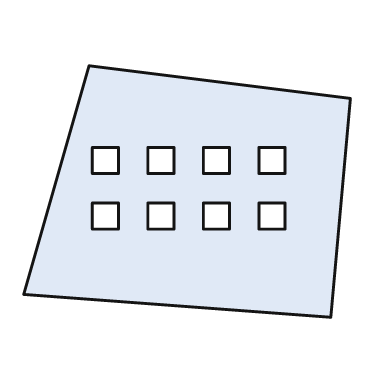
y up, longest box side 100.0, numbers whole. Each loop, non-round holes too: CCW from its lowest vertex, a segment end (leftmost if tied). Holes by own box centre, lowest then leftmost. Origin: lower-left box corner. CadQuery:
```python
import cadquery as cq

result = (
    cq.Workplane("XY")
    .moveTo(94.0, 0.0)
    .lineTo(100.0, 67.0)
    .lineTo(20.0, 77.0)
    .lineTo(0.0, 7.0)
    .close()
    .moveTo(21.0, 27.0)
    .lineTo(29.0, 27.0)
    .lineTo(29.0, 35.0)
    .lineTo(21.0, 35.0)
    .close()
    .moveTo(38.0, 27.0)
    .lineTo(46.0, 27.0)
    .lineTo(46.0, 35.0)
    .lineTo(38.0, 35.0)
    .close()
    .moveTo(55.0, 27.0)
    .lineTo(63.0, 27.0)
    .lineTo(63.0, 35.0)
    .lineTo(55.0, 35.0)
    .close()
    .moveTo(72.0, 27.0)
    .lineTo(80.0, 27.0)
    .lineTo(80.0, 35.0)
    .lineTo(72.0, 35.0)
    .close()
    .moveTo(21.0, 44.0)
    .lineTo(29.0, 44.0)
    .lineTo(29.0, 52.0)
    .lineTo(21.0, 52.0)
    .close()
    .moveTo(38.0, 44.0)
    .lineTo(46.0, 44.0)
    .lineTo(46.0, 52.0)
    .lineTo(38.0, 52.0)
    .close()
    .moveTo(55.0, 44.0)
    .lineTo(63.0, 44.0)
    .lineTo(63.0, 52.0)
    .lineTo(55.0, 52.0)
    .close()
    .moveTo(72.0, 44.0)
    .lineTo(80.0, 44.0)
    .lineTo(80.0, 52.0)
    .lineTo(72.0, 52.0)
    .close()
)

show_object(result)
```